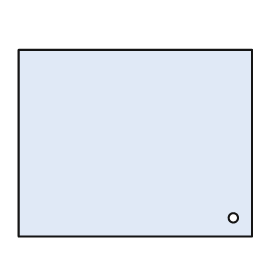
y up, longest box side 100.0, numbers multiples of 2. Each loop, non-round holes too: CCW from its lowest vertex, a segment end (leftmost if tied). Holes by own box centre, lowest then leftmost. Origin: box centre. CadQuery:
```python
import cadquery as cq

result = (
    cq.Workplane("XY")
    .moveTo(-50.0, -40.0)
    .lineTo(50.0, -40.0)
    .lineTo(50.0, 40.0)
    .lineTo(-50.0, 40.0)
    .close()
    .moveTo(42.0, -32.0)
    .circle(2.0)
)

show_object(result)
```